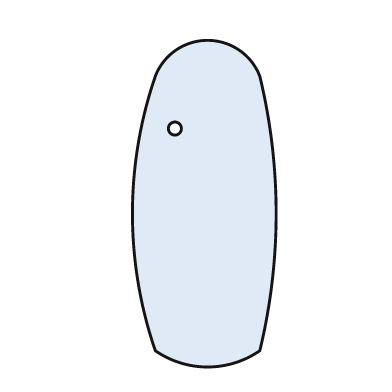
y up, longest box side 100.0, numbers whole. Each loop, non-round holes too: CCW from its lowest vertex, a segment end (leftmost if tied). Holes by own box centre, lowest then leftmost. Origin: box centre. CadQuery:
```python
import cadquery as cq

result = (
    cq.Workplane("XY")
    .moveTo(-15.0, -45.0)
    .threePointArc((1.0, -50.0), (17.0, -45.0))
    .threePointArc((22.0, -3.0), (17.0, 39.0))
    .threePointArc((1.0, 50.0), (-15.0, 39.0))
    .threePointArc((-22.0, -3.0), (-15.0, -45.0))
    .close()
    .moveTo(-9.0, 23.0)
    .circle(2.0)
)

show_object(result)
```